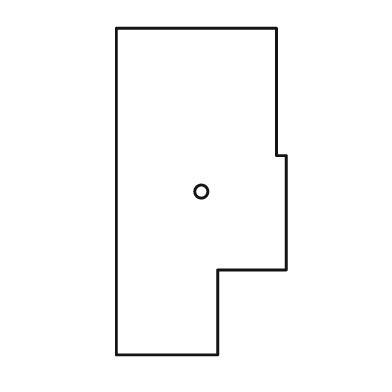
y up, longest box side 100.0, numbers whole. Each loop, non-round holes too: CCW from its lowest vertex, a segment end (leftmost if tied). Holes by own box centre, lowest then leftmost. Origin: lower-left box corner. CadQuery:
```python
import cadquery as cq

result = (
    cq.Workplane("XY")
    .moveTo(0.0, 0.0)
    .lineTo(31.0, 0.0)
    .lineTo(31.0, 26.0)
    .lineTo(52.0, 26.0)
    .lineTo(52.0, 61.0)
    .lineTo(49.0, 61.0)
    .lineTo(49.0, 100.0)
    .lineTo(0.0, 100.0)
    .close()
    .moveTo(26.0, 50.0)
    .circle(2.0)
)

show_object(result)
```